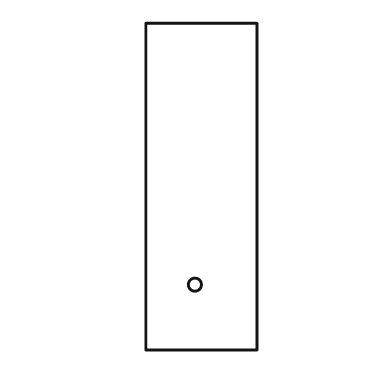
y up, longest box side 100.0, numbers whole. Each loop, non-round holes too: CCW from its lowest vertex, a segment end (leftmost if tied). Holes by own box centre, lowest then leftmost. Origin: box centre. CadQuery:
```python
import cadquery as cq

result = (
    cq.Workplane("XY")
    .moveTo(-17.0, -50.0)
    .lineTo(17.0, -50.0)
    .lineTo(17.0, 50.0)
    .lineTo(-17.0, 50.0)
    .close()
    .moveTo(-2.0, -30.0)
    .circle(2.0)
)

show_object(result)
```